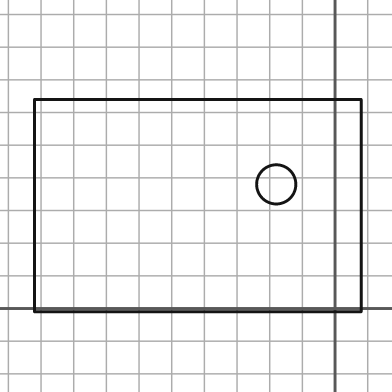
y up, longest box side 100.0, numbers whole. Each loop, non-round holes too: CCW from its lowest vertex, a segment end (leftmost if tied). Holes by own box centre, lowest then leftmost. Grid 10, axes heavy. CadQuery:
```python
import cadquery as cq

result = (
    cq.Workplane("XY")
    .moveTo(-92.0, -1.0)
    .lineTo(8.0, -1.0)
    .lineTo(8.0, 64.0)
    .lineTo(-92.0, 64.0)
    .close()
    .moveTo(-18.0, 38.0)
    .circle(6.0)
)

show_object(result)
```